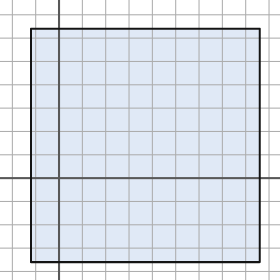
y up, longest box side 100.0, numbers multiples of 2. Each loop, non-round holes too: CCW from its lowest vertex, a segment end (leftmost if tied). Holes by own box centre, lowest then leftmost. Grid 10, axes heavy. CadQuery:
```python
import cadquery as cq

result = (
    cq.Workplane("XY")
    .moveTo(-12.0, -36.0)
    .lineTo(86.0, -36.0)
    .lineTo(86.0, 64.0)
    .lineTo(-12.0, 64.0)
    .close()
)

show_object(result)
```